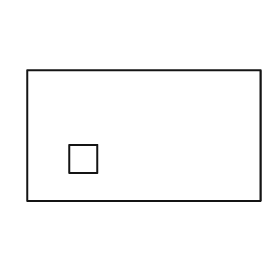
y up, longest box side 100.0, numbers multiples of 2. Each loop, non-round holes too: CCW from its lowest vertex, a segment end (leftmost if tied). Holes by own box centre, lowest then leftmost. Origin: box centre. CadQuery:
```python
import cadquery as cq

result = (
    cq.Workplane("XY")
    .moveTo(-50.0, -28.0)
    .lineTo(50.0, -28.0)
    .lineTo(50.0, 28.0)
    .lineTo(-50.0, 28.0)
    .close()
    .moveTo(-32.0, -16.0)
    .lineTo(-20.0, -16.0)
    .lineTo(-20.0, -4.0)
    .lineTo(-32.0, -4.0)
    .close()
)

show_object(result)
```